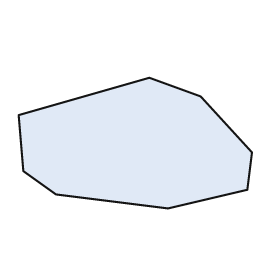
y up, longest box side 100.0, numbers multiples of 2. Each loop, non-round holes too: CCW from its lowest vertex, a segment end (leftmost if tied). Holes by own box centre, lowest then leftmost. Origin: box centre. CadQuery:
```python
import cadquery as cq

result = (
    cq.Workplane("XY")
    .moveTo(14.0, -28.0)
    .lineTo(48.0, -20.0)
    .lineTo(50.0, -4.0)
    .lineTo(28.0, 20.0)
    .lineTo(6.0, 28.0)
    .lineTo(-50.0, 12.0)
    .lineTo(-48.0, -12.0)
    .lineTo(-34.0, -22.0)
    .close()
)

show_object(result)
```